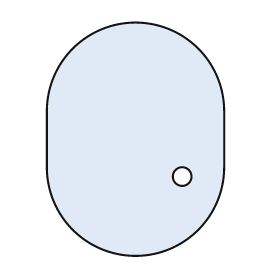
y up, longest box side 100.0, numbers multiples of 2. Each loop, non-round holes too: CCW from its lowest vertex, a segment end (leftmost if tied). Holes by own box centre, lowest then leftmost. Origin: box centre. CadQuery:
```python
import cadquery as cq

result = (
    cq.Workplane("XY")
    .moveTo(-38.0, -12.0)
    .threePointArc((0.0, -50.0), (38.0, -12.0))
    .lineTo(38.0, 12.0)
    .threePointArc((0.0, 50.0), (-38.0, 12.0))
    .close()
    .moveTo(20.0, -16.0)
    .circle(4.0)
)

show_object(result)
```